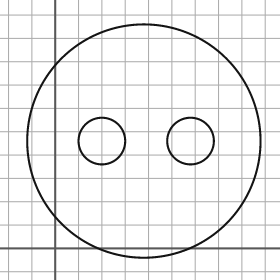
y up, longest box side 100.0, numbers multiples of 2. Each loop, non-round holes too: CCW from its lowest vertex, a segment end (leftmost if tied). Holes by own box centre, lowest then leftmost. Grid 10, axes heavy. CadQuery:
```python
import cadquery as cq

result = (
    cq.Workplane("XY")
    .moveTo(38.0, 46.0)
    .circle(50.0)
    .moveTo(20.0, 46.0)
    .circle(10.0)
    .moveTo(58.0, 46.0)
    .circle(10.0)
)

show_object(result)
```